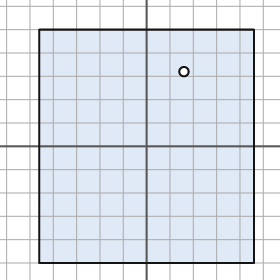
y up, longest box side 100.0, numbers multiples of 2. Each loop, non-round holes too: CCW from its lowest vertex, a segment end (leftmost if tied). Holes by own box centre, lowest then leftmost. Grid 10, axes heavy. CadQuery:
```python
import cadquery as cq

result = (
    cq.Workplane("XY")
    .moveTo(-46.0, -50.0)
    .lineTo(46.0, -50.0)
    .lineTo(46.0, 50.0)
    .lineTo(-46.0, 50.0)
    .close()
    .moveTo(16.0, 32.0)
    .circle(2.0)
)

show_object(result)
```